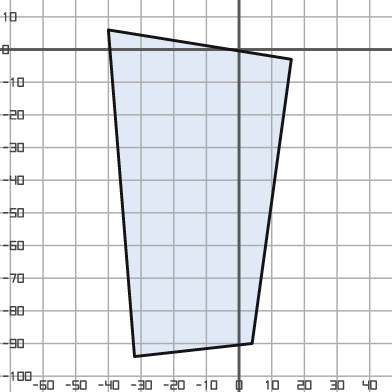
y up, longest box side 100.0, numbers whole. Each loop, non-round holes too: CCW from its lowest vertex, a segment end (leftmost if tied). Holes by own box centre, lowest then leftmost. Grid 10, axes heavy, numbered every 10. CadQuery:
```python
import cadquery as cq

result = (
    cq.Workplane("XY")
    .moveTo(-32.0, -94.0)
    .lineTo(4.0, -90.0)
    .lineTo(16.0, -3.0)
    .lineTo(-40.0, 6.0)
    .close()
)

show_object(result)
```